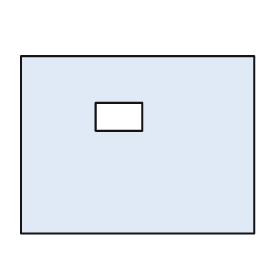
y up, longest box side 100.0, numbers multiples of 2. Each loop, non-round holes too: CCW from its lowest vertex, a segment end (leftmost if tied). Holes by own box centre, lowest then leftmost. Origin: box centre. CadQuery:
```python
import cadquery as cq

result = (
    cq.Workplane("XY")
    .moveTo(-50.0, -38.0)
    .lineTo(50.0, -38.0)
    .lineTo(50.0, 38.0)
    .lineTo(-50.0, 38.0)
    .close()
    .moveTo(-18.0, 6.0)
    .lineTo(2.0, 6.0)
    .lineTo(2.0, 18.0)
    .lineTo(-18.0, 18.0)
    .close()
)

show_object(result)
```